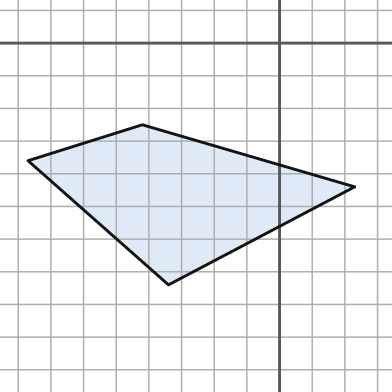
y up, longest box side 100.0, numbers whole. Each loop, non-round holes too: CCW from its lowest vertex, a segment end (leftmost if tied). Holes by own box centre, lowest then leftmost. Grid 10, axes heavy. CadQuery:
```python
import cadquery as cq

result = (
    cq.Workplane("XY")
    .moveTo(-34.0, -74.0)
    .lineTo(23.0, -44.0)
    .lineTo(-42.0, -25.0)
    .lineTo(-77.0, -36.0)
    .close()
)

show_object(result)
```